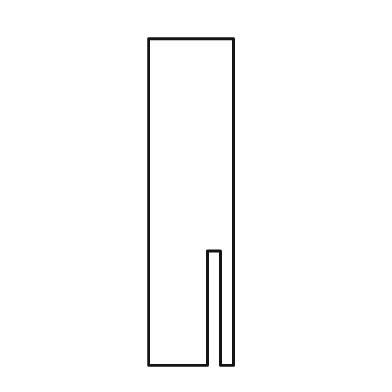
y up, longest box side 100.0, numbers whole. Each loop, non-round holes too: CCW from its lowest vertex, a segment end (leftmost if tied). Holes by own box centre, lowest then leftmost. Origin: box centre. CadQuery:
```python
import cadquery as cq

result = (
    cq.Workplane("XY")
    .moveTo(-13.0, -50.0)
    .lineTo(5.0, -50.0)
    .lineTo(5.0, -15.0)
    .lineTo(9.0, -15.0)
    .lineTo(9.0, -50.0)
    .lineTo(13.0, -50.0)
    .lineTo(13.0, 50.0)
    .lineTo(-13.0, 50.0)
    .close()
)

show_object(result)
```